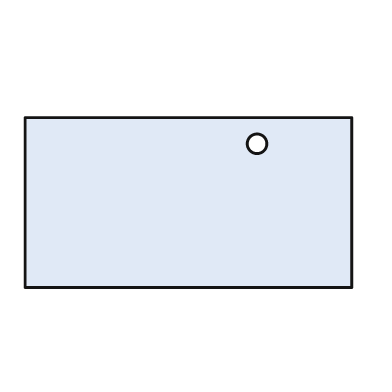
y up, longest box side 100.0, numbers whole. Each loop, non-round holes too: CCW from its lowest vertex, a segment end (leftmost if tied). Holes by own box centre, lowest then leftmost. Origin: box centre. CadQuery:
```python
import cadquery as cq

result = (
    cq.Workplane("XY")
    .moveTo(-50.0, -26.0)
    .lineTo(50.0, -26.0)
    .lineTo(50.0, 26.0)
    .lineTo(-50.0, 26.0)
    .close()
    .moveTo(21.0, 18.0)
    .circle(3.0)
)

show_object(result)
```